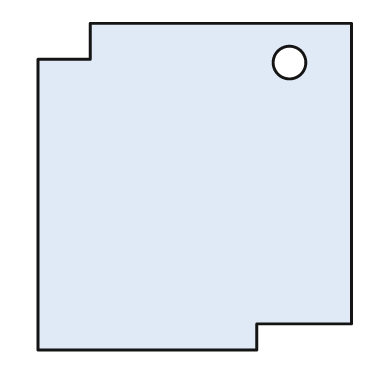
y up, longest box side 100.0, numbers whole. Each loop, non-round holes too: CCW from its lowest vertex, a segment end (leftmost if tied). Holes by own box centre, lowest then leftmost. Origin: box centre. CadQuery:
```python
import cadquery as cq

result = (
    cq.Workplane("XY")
    .moveTo(-48.0, -50.0)
    .lineTo(19.0, -50.0)
    .lineTo(19.0, -42.0)
    .lineTo(48.0, -42.0)
    .lineTo(48.0, 50.0)
    .lineTo(-32.0, 50.0)
    .lineTo(-32.0, 39.0)
    .lineTo(-48.0, 39.0)
    .close()
    .moveTo(29.0, 38.0)
    .circle(5.0)
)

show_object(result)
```